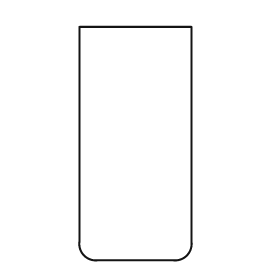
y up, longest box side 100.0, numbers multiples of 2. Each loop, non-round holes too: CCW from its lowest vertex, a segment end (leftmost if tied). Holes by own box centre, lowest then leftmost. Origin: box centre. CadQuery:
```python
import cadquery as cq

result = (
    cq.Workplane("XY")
    .moveTo(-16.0, -50.0)
    .lineTo(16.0, -50.0)
    .threePointArc((22.0, -48.0), (24.0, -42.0))
    .lineTo(24.0, 50.0)
    .lineTo(-24.0, 50.0)
    .lineTo(-24.0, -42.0)
    .threePointArc((-22.0, -48.0), (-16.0, -50.0))
    .close()
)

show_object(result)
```